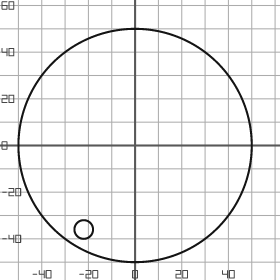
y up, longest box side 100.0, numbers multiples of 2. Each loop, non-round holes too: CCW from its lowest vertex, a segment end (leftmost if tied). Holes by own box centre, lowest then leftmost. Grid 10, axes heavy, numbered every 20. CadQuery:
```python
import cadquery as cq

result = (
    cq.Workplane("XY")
    .moveTo(0.0, 0.0)
    .circle(50.0)
    .moveTo(-22.0, -36.0)
    .circle(4.0)
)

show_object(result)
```